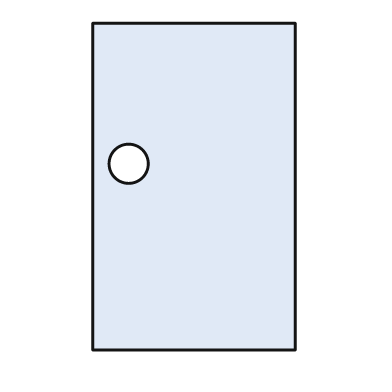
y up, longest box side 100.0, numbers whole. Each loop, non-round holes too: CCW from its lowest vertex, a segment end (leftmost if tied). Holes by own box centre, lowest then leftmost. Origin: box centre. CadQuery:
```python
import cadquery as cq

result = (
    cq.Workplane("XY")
    .moveTo(-31.0, -50.0)
    .lineTo(31.0, -50.0)
    .lineTo(31.0, 50.0)
    .lineTo(-31.0, 50.0)
    .close()
    .moveTo(-20.0, 7.0)
    .circle(6.0)
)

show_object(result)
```